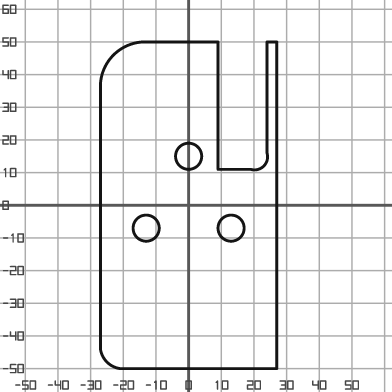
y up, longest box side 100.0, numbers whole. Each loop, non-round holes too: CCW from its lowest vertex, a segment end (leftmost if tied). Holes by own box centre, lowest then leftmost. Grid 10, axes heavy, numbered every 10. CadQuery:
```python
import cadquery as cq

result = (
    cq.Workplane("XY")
    .moveTo(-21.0, -50.0)
    .lineTo(27.0, -50.0)
    .lineTo(27.0, 50.0)
    .lineTo(24.0, 50.0)
    .lineTo(24.0, 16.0)
    .threePointArc((23.0, 12.0), (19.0, 11.0))
    .lineTo(9.0, 11.0)
    .lineTo(9.0, 50.0)
    .lineTo(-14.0, 50.0)
    .threePointArc((-23.0, 46.0), (-27.0, 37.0))
    .lineTo(-27.0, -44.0)
    .threePointArc((-25.0, -48.0), (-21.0, -50.0))
    .close()
    .moveTo(-13.0, -7.0)
    .circle(4.0)
    .moveTo(13.0, -7.0)
    .circle(4.0)
    .moveTo(0.0, 15.0)
    .circle(4.0)
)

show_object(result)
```